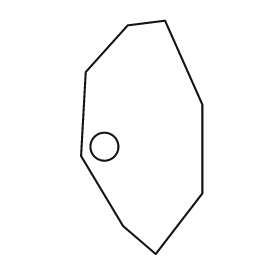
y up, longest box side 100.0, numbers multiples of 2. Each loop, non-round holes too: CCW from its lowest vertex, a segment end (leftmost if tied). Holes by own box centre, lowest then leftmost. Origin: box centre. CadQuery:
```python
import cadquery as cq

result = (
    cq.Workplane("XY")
    .moveTo(6.0, -50.0)
    .lineTo(26.0, -24.0)
    .lineTo(26.0, 14.0)
    .lineTo(10.0, 50.0)
    .lineTo(-6.0, 48.0)
    .lineTo(-24.0, 28.0)
    .lineTo(-26.0, -8.0)
    .lineTo(-8.0, -38.0)
    .close()
    .moveTo(-16.0, -4.0)
    .circle(6.0)
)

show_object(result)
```